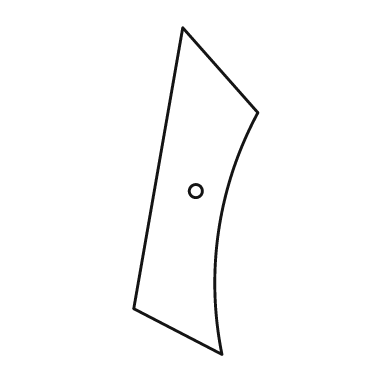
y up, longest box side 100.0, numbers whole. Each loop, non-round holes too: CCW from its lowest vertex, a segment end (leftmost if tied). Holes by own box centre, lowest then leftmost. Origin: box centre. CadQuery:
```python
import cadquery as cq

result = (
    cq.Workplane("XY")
    .moveTo(8.0, -50.0)
    .threePointArc((7.0, -12.0), (19.0, 24.0))
    .lineTo(-4.0, 50.0)
    .lineTo(-19.0, -36.0)
    .close()
    .moveTo(0.0, 0.0)
    .circle(2.0)
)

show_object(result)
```